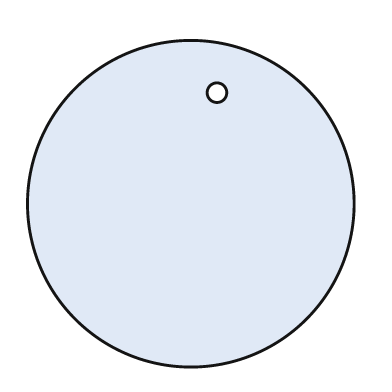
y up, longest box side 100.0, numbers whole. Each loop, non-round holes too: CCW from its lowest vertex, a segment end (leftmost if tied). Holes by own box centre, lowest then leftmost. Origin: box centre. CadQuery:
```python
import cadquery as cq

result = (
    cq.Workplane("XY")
    .moveTo(0.0, 0.0)
    .circle(50.0)
    .moveTo(8.0, 34.0)
    .circle(3.0)
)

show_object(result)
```